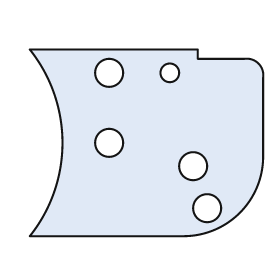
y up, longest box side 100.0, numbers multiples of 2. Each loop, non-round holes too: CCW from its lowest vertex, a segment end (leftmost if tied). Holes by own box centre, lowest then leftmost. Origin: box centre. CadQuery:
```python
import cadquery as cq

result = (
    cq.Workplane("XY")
    .moveTo(-50.0, -40.0)
    .lineTo(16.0, -40.0)
    .threePointArc((40.0, -30.0), (50.0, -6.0))
    .lineTo(50.0, 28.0)
    .threePointArc((48.0, 34.0), (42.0, 36.0))
    .lineTo(22.0, 36.0)
    .lineTo(22.0, 40.0)
    .lineTo(-50.0, 40.0)
    .threePointArc((-36.0, 0.0), (-50.0, -40.0))
    .close()
    .moveTo(26.0, -28.0)
    .circle(6.0)
    .moveTo(20.0, -10.0)
    .circle(6.0)
    .moveTo(-16.0, 0.0)
    .circle(6.0)
    .moveTo(-16.0, 30.0)
    .circle(6.0)
    .moveTo(10.0, 30.0)
    .circle(4.0)
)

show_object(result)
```